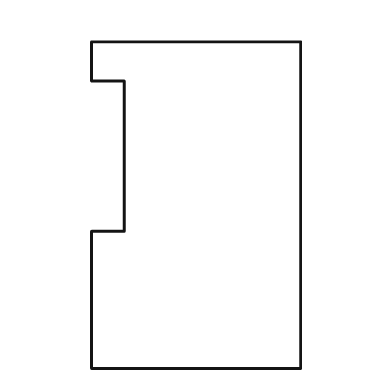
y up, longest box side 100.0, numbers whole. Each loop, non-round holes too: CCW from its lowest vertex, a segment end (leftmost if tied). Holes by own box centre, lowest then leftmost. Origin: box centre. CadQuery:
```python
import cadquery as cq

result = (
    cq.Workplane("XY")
    .moveTo(-32.0, -50.0)
    .lineTo(32.0, -50.0)
    .lineTo(32.0, 50.0)
    .lineTo(-32.0, 50.0)
    .lineTo(-32.0, 38.0)
    .lineTo(-22.0, 38.0)
    .lineTo(-22.0, -8.0)
    .lineTo(-32.0, -8.0)
    .close()
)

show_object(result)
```